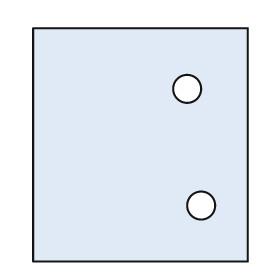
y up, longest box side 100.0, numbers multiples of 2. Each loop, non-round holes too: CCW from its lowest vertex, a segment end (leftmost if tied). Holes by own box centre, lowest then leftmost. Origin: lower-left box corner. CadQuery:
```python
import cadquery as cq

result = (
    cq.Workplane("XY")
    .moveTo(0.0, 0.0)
    .lineTo(92.0, 0.0)
    .lineTo(92.0, 100.0)
    .lineTo(0.0, 100.0)
    .close()
    .moveTo(72.0, 24.0)
    .circle(6.0)
    .moveTo(66.0, 74.0)
    .circle(6.0)
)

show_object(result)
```